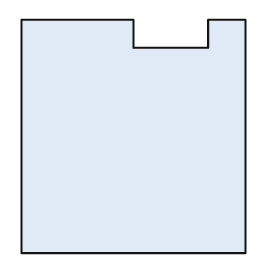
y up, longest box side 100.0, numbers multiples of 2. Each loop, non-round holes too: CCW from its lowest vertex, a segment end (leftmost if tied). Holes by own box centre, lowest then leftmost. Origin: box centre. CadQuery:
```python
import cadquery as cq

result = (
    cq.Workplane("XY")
    .moveTo(-48.0, -50.0)
    .lineTo(48.0, -50.0)
    .lineTo(48.0, 50.0)
    .lineTo(32.0, 50.0)
    .lineTo(32.0, 38.0)
    .lineTo(0.0, 38.0)
    .lineTo(0.0, 50.0)
    .lineTo(-48.0, 50.0)
    .close()
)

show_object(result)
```